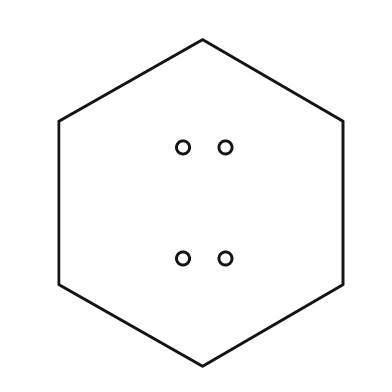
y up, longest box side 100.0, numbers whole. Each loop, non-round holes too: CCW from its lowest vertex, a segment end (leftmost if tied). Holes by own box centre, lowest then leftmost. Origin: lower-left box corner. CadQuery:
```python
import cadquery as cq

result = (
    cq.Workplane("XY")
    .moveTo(44.0, 0.0)
    .lineTo(87.0, 25.0)
    .lineTo(87.0, 75.0)
    .lineTo(44.0, 100.0)
    .lineTo(0.0, 75.0)
    .lineTo(0.0, 25.0)
    .close()
    .moveTo(38.0, 33.0)
    .circle(2.0)
    .moveTo(51.0, 33.0)
    .circle(2.0)
    .moveTo(38.0, 67.0)
    .circle(2.0)
    .moveTo(51.0, 67.0)
    .circle(2.0)
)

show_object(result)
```